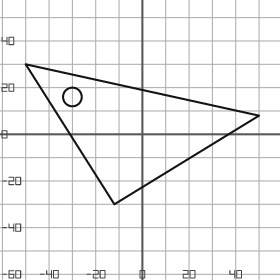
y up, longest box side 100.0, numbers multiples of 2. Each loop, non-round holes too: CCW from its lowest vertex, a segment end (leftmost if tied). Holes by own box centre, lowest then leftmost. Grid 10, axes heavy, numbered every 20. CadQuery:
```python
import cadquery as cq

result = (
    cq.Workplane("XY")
    .moveTo(-12.0, -30.0)
    .lineTo(50.0, 8.0)
    .lineTo(-50.0, 30.0)
    .close()
    .moveTo(-30.0, 16.0)
    .circle(4.0)
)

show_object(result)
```